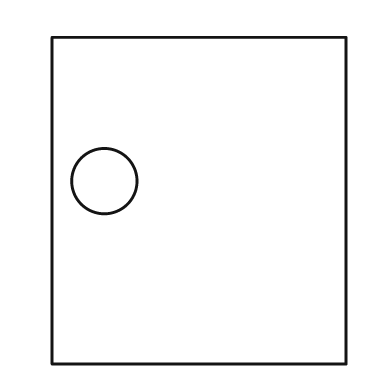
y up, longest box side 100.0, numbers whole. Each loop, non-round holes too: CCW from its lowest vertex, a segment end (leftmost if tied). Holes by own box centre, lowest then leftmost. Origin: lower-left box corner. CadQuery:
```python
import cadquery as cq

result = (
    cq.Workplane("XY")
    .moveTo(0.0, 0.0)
    .lineTo(90.0, 0.0)
    .lineTo(90.0, 100.0)
    .lineTo(0.0, 100.0)
    .close()
    .moveTo(16.0, 56.0)
    .circle(10.0)
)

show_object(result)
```